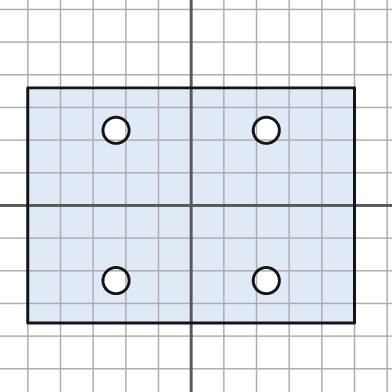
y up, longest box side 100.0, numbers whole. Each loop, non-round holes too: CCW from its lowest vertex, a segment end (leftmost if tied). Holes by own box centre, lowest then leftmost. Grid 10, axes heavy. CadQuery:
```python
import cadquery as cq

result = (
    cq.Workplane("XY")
    .moveTo(-50.0, -36.0)
    .lineTo(50.0, -36.0)
    .lineTo(50.0, 36.0)
    .lineTo(-50.0, 36.0)
    .close()
    .moveTo(-23.0, -23.0)
    .circle(4.0)
    .moveTo(23.0, -23.0)
    .circle(4.0)
    .moveTo(-23.0, 23.0)
    .circle(4.0)
    .moveTo(23.0, 23.0)
    .circle(4.0)
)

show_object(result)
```